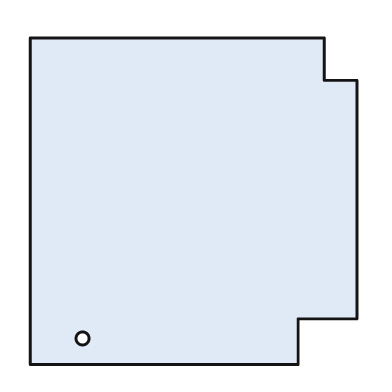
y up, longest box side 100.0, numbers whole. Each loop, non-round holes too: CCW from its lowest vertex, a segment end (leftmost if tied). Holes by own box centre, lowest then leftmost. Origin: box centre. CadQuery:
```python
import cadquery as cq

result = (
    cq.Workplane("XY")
    .moveTo(-50.0, -50.0)
    .lineTo(32.0, -50.0)
    .lineTo(32.0, -36.0)
    .lineTo(50.0, -36.0)
    .lineTo(50.0, 37.0)
    .lineTo(40.0, 37.0)
    .lineTo(40.0, 50.0)
    .lineTo(-50.0, 50.0)
    .close()
    .moveTo(-34.0, -42.0)
    .circle(2.0)
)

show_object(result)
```